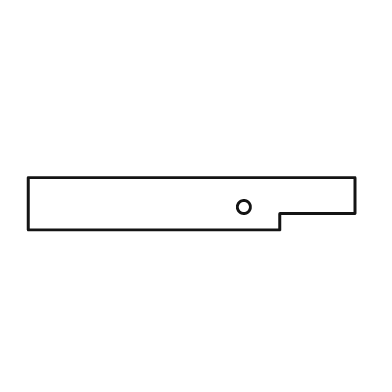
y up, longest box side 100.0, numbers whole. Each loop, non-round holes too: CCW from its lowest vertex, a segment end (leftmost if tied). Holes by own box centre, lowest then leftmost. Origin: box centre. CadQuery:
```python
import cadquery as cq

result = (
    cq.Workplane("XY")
    .moveTo(-50.0, -8.0)
    .lineTo(27.0, -8.0)
    .lineTo(27.0, -3.0)
    .lineTo(50.0, -3.0)
    .lineTo(50.0, 8.0)
    .lineTo(-50.0, 8.0)
    .close()
    .moveTo(16.0, -1.0)
    .circle(2.0)
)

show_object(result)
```